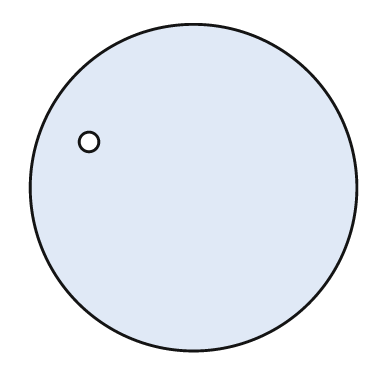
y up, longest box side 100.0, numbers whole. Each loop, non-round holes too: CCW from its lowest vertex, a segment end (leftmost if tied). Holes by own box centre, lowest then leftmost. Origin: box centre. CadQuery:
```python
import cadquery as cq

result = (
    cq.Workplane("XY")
    .moveTo(0.0, 0.0)
    .circle(50.0)
    .moveTo(-32.0, 14.0)
    .circle(3.0)
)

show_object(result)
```